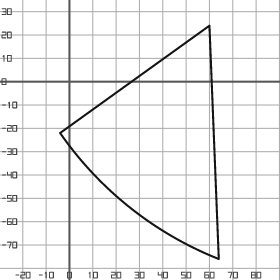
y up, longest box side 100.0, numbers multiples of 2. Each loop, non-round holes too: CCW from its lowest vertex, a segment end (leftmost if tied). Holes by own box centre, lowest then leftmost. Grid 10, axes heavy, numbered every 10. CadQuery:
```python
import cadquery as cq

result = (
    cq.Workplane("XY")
    .moveTo(64.0, -76.0)
    .lineTo(60.0, 24.0)
    .lineTo(-4.0, -22.0)
    .threePointArc((26.0, -54.0), (64.0, -76.0))
    .close()
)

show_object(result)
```